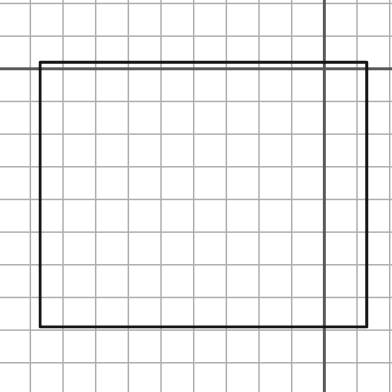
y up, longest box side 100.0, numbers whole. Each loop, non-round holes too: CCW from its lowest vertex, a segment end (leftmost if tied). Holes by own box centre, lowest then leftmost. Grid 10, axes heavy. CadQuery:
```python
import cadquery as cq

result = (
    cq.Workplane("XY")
    .moveTo(-87.0, -79.0)
    .lineTo(13.0, -79.0)
    .lineTo(13.0, 2.0)
    .lineTo(-87.0, 2.0)
    .close()
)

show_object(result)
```